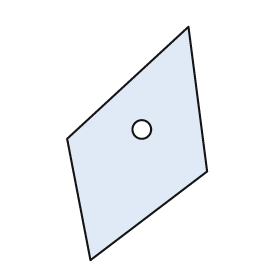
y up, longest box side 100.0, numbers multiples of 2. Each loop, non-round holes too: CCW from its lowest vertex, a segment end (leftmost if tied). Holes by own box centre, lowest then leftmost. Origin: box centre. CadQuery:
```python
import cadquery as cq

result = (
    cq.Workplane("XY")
    .moveTo(-20.0, -50.0)
    .lineTo(30.0, -12.0)
    .lineTo(22.0, 50.0)
    .lineTo(-30.0, 2.0)
    .close()
    .moveTo(2.0, 6.0)
    .circle(4.0)
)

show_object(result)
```